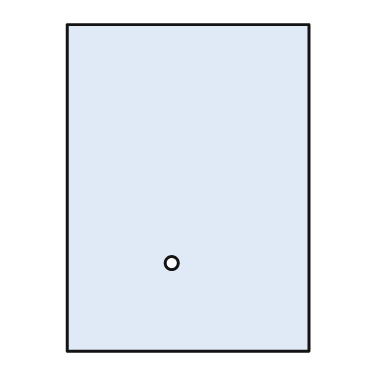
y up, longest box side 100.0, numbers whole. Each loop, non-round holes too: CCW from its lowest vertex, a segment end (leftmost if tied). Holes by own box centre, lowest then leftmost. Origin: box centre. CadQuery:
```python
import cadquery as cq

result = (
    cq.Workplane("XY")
    .moveTo(-37.0, -50.0)
    .lineTo(37.0, -50.0)
    .lineTo(37.0, 50.0)
    .lineTo(-37.0, 50.0)
    .close()
    .moveTo(-5.0, -23.0)
    .circle(2.0)
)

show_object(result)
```